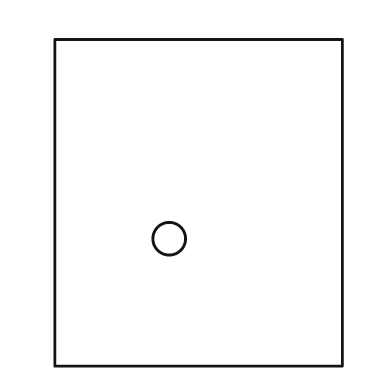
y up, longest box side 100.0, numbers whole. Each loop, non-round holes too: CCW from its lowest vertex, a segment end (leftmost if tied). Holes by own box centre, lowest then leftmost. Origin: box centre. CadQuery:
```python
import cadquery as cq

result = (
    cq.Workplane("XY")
    .moveTo(-44.0, -50.0)
    .lineTo(44.0, -50.0)
    .lineTo(44.0, 50.0)
    .lineTo(-44.0, 50.0)
    .close()
    .moveTo(-9.0, -11.0)
    .circle(5.0)
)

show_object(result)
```